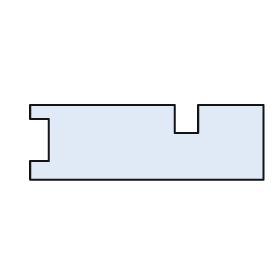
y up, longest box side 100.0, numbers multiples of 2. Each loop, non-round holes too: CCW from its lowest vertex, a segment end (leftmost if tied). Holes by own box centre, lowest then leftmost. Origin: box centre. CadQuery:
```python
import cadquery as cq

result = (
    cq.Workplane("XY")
    .moveTo(-50.0, -16.0)
    .lineTo(50.0, -16.0)
    .lineTo(50.0, 16.0)
    .lineTo(22.0, 16.0)
    .lineTo(22.0, 4.0)
    .lineTo(12.0, 4.0)
    .lineTo(12.0, 16.0)
    .lineTo(-50.0, 16.0)
    .lineTo(-50.0, 10.0)
    .lineTo(-42.0, 10.0)
    .lineTo(-42.0, -8.0)
    .lineTo(-50.0, -8.0)
    .close()
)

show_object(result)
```